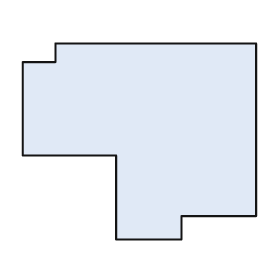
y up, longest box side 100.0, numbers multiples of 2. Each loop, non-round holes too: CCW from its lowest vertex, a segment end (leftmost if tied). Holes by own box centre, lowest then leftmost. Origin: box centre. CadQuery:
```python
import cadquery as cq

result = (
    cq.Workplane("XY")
    .moveTo(-10.0, -42.0)
    .lineTo(18.0, -42.0)
    .lineTo(18.0, -32.0)
    .lineTo(50.0, -32.0)
    .lineTo(50.0, 42.0)
    .lineTo(-36.0, 42.0)
    .lineTo(-36.0, 34.0)
    .lineTo(-50.0, 34.0)
    .lineTo(-50.0, -6.0)
    .lineTo(-10.0, -6.0)
    .close()
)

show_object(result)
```